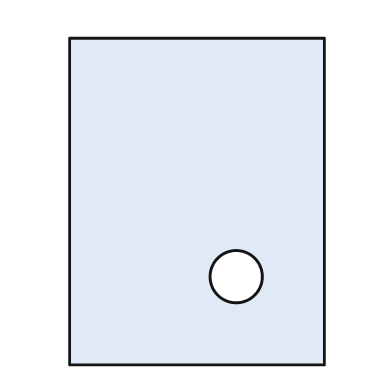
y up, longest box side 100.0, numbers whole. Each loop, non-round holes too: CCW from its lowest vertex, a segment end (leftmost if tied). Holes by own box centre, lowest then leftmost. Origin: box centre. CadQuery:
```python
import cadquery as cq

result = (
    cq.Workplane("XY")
    .moveTo(-39.0, -50.0)
    .lineTo(39.0, -50.0)
    .lineTo(39.0, 50.0)
    .lineTo(-39.0, 50.0)
    .close()
    .moveTo(12.0, -23.0)
    .circle(8.0)
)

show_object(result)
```